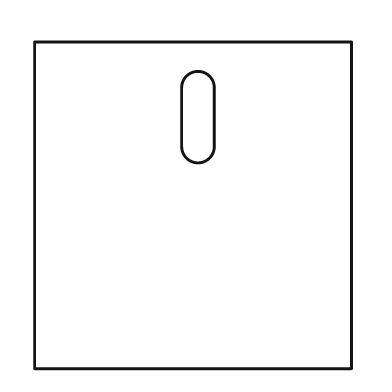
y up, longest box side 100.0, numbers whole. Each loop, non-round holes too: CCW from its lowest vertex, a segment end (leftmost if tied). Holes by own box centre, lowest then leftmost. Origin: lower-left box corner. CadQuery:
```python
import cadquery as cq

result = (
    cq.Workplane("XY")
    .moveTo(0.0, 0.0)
    .lineTo(97.0, 0.0)
    .lineTo(97.0, 100.0)
    .lineTo(0.0, 100.0)
    .close()
    .moveTo(45.0, 68.0)
    .threePointArc((50.0, 63.0), (55.0, 68.0))
    .lineTo(55.0, 86.0)
    .threePointArc((50.0, 91.0), (45.0, 86.0))
    .close()
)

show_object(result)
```